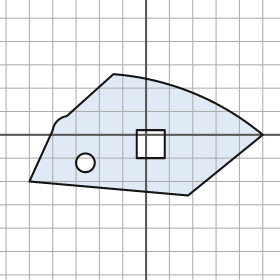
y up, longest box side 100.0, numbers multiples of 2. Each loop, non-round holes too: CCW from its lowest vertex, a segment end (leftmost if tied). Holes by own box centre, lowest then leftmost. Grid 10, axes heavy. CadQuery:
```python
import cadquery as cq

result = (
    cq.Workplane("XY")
    .moveTo(18.0, -26.0)
    .lineTo(50.0, 0.0)
    .threePointArc((20.0, 18.0), (-14.0, 26.0))
    .lineTo(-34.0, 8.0)
    .threePointArc((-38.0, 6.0), (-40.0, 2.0))
    .lineTo(-50.0, -20.0)
    .close()
    .moveTo(-26.0, -12.0)
    .circle(4.0)
    .moveTo(-4.0, -10.0)
    .lineTo(8.0, -10.0)
    .lineTo(8.0, 2.0)
    .lineTo(-4.0, 2.0)
    .close()
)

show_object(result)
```